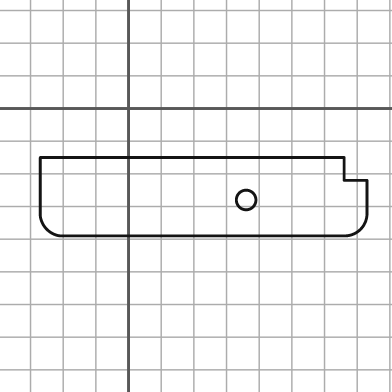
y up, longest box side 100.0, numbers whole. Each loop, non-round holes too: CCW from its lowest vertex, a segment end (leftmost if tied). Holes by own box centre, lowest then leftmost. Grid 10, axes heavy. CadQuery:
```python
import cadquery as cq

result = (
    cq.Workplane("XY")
    .moveTo(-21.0, -39.0)
    .lineTo(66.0, -39.0)
    .threePointArc((71.0, -37.0), (73.0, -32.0))
    .lineTo(73.0, -22.0)
    .lineTo(66.0, -22.0)
    .lineTo(66.0, -15.0)
    .lineTo(-27.0, -15.0)
    .lineTo(-27.0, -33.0)
    .threePointArc((-25.0, -37.0), (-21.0, -39.0))
    .close()
    .moveTo(36.0, -28.0)
    .circle(3.0)
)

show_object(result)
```